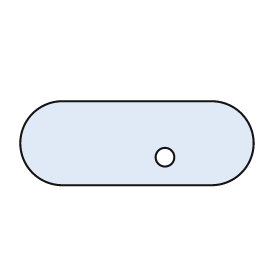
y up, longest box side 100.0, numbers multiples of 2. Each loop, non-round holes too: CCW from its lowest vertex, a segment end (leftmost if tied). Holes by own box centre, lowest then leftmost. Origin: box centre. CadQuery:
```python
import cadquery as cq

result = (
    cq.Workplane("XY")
    .moveTo(-32.0, -18.0)
    .lineTo(32.0, -18.0)
    .threePointArc((50.0, 0.0), (32.0, 18.0))
    .lineTo(-32.0, 18.0)
    .threePointArc((-50.0, 0.0), (-32.0, -18.0))
    .close()
    .moveTo(12.0, -6.0)
    .circle(4.0)
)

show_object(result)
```